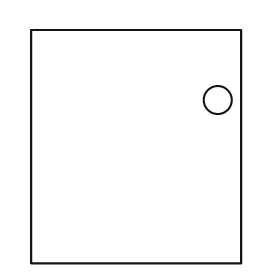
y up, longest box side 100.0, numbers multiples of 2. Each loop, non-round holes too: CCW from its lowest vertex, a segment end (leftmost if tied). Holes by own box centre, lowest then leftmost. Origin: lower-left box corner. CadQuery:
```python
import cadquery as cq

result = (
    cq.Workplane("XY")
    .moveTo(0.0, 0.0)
    .lineTo(90.0, 0.0)
    .lineTo(90.0, 100.0)
    .lineTo(0.0, 100.0)
    .close()
    .moveTo(80.0, 70.0)
    .circle(6.0)
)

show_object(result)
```